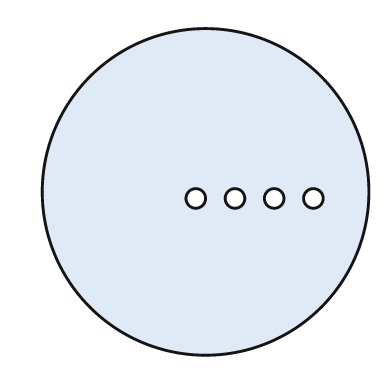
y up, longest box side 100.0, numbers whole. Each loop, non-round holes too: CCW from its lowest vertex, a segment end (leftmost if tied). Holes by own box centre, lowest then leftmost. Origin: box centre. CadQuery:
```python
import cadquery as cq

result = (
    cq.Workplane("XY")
    .moveTo(0.0, 0.0)
    .circle(50.0)
    .moveTo(-3.0, -2.0)
    .circle(3.0)
    .moveTo(9.0, -2.0)
    .circle(3.0)
    .moveTo(21.0, -2.0)
    .circle(3.0)
    .moveTo(33.0, -2.0)
    .circle(3.0)
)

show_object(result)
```